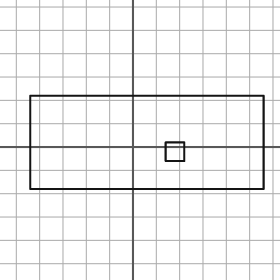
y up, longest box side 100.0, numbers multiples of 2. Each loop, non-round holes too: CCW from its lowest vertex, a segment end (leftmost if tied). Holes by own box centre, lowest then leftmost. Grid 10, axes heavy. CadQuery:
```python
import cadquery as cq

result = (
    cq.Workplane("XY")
    .moveTo(-44.0, -18.0)
    .lineTo(56.0, -18.0)
    .lineTo(56.0, 22.0)
    .lineTo(-44.0, 22.0)
    .close()
    .moveTo(14.0, -6.0)
    .lineTo(22.0, -6.0)
    .lineTo(22.0, 2.0)
    .lineTo(14.0, 2.0)
    .close()
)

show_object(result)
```